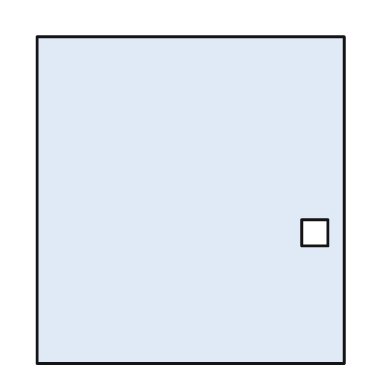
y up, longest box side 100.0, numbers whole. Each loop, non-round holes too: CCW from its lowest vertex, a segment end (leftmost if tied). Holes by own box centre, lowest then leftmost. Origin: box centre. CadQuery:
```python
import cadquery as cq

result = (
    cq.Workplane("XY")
    .moveTo(-47.0, -50.0)
    .lineTo(47.0, -50.0)
    .lineTo(47.0, 50.0)
    .lineTo(-47.0, 50.0)
    .close()
    .moveTo(34.0, -14.0)
    .lineTo(42.0, -14.0)
    .lineTo(42.0, -6.0)
    .lineTo(34.0, -6.0)
    .close()
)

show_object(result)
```